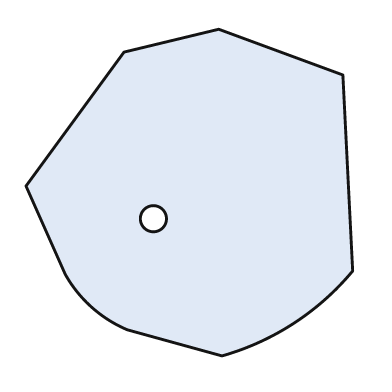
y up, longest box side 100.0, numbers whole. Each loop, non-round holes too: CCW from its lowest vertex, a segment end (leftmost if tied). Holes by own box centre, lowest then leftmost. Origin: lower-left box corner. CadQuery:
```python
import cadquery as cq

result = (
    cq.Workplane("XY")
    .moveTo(60.0, 0.0)
    .threePointArc((82.0, 10.0), (100.0, 26.0))
    .lineTo(97.0, 86.0)
    .lineTo(59.0, 100.0)
    .lineTo(30.0, 93.0)
    .lineTo(0.0, 52.0)
    .lineTo(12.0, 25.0)
    .threePointArc((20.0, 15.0), (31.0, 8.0))
    .close()
    .moveTo(39.0, 42.0)
    .circle(4.0)
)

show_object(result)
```